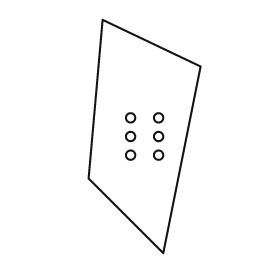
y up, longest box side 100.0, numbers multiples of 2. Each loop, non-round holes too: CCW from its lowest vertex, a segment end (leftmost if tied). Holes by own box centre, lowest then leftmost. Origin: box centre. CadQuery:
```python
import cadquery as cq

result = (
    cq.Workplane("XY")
    .moveTo(8.0, -50.0)
    .lineTo(24.0, 30.0)
    .lineTo(-18.0, 50.0)
    .lineTo(-24.0, -18.0)
    .close()
    .moveTo(-6.0, -8.0)
    .circle(2.0)
    .moveTo(6.0, -8.0)
    .circle(2.0)
    .moveTo(-6.0, 0.0)
    .circle(2.0)
    .moveTo(6.0, 0.0)
    .circle(2.0)
    .moveTo(-6.0, 8.0)
    .circle(2.0)
    .moveTo(6.0, 8.0)
    .circle(2.0)
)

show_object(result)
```